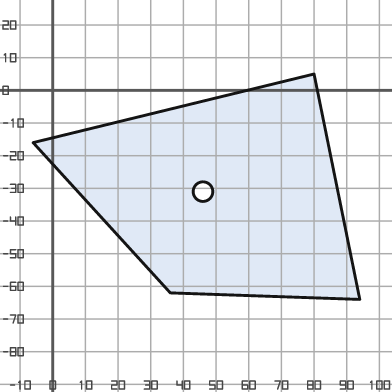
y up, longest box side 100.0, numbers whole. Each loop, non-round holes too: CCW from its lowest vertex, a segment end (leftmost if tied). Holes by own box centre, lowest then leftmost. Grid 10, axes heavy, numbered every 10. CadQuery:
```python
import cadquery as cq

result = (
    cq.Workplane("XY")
    .moveTo(94.0, -64.0)
    .lineTo(80.0, 5.0)
    .lineTo(-6.0, -16.0)
    .lineTo(36.0, -62.0)
    .close()
    .moveTo(46.0, -31.0)
    .circle(3.0)
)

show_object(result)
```